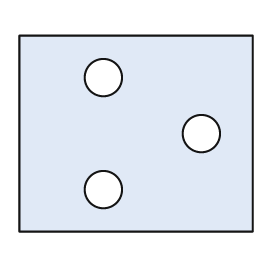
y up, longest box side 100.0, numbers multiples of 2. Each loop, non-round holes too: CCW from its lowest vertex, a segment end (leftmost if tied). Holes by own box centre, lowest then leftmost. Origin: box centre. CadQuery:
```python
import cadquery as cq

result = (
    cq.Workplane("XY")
    .moveTo(-50.0, -42.0)
    .lineTo(50.0, -42.0)
    .lineTo(50.0, 42.0)
    .lineTo(-50.0, 42.0)
    .close()
    .moveTo(-14.0, -24.0)
    .circle(8.0)
    .moveTo(28.0, 0.0)
    .circle(8.0)
    .moveTo(-14.0, 24.0)
    .circle(8.0)
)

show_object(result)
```